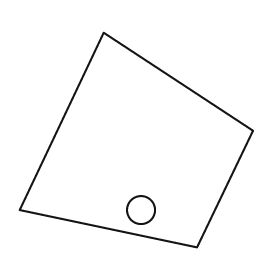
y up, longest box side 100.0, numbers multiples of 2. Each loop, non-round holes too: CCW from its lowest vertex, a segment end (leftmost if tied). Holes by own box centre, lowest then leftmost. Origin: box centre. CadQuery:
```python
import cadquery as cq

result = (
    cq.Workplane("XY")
    .moveTo(26.0, -46.0)
    .lineTo(50.0, 4.0)
    .lineTo(-14.0, 46.0)
    .lineTo(-50.0, -30.0)
    .close()
    .moveTo(2.0, -30.0)
    .circle(6.0)
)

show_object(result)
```